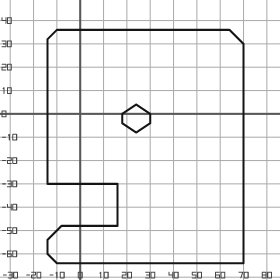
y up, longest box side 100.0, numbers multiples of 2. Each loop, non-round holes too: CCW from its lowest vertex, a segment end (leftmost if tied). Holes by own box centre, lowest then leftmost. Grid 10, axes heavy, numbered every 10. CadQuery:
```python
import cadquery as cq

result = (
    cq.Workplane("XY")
    .moveTo(-10.0, -64.0)
    .lineTo(70.0, -64.0)
    .lineTo(70.0, 30.0)
    .lineTo(64.0, 36.0)
    .lineTo(-10.0, 36.0)
    .lineTo(-14.0, 32.0)
    .lineTo(-14.0, -30.0)
    .lineTo(16.0, -30.0)
    .lineTo(16.0, -48.0)
    .lineTo(-8.0, -48.0)
    .lineTo(-14.0, -54.0)
    .lineTo(-14.0, -60.0)
    .close()
    .moveTo(24.0, -8.0)
    .lineTo(30.0, -4.0)
    .lineTo(30.0, 0.0)
    .lineTo(24.0, 4.0)
    .lineTo(18.0, 0.0)
    .lineTo(18.0, -4.0)
    .close()
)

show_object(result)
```